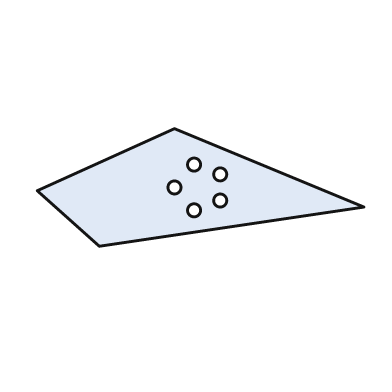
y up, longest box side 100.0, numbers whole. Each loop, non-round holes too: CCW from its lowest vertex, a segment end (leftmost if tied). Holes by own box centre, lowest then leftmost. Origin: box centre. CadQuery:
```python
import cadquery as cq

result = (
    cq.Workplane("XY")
    .moveTo(-31.0, -18.0)
    .lineTo(50.0, -6.0)
    .lineTo(-8.0, 18.0)
    .lineTo(-50.0, -1.0)
    .close()
    .moveTo(-2.0, -7.0)
    .circle(2.0)
    .moveTo(6.0, -4.0)
    .circle(2.0)
    .moveTo(-8.0, 0.0)
    .circle(2.0)
    .moveTo(6.0, 4.0)
    .circle(2.0)
    .moveTo(-2.0, 7.0)
    .circle(2.0)
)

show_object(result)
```